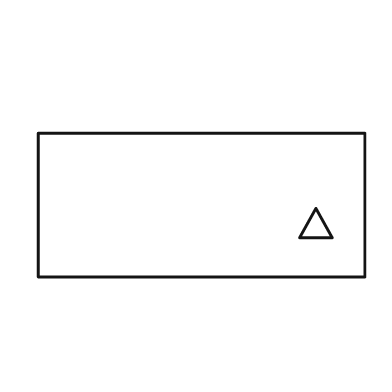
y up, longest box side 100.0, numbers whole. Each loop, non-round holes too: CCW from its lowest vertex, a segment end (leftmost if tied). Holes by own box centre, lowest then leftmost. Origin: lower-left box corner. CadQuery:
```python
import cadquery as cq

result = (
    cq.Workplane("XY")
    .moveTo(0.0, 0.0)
    .lineTo(100.0, 0.0)
    .lineTo(100.0, 44.0)
    .lineTo(0.0, 44.0)
    .close()
    .moveTo(80.0, 12.0)
    .lineTo(90.0, 12.0)
    .lineTo(85.0, 21.0)
    .close()
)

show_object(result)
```